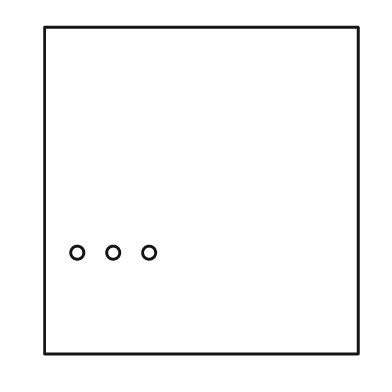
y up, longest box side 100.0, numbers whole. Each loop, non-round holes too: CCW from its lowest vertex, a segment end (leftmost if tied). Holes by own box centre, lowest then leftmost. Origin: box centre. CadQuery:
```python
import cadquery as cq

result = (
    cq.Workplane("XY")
    .moveTo(-48.0, -50.0)
    .lineTo(48.0, -50.0)
    .lineTo(48.0, 50.0)
    .lineTo(-48.0, 50.0)
    .close()
    .moveTo(-38.0, -19.0)
    .circle(2.0)
    .moveTo(-27.0, -19.0)
    .circle(2.0)
    .moveTo(-16.0, -19.0)
    .circle(2.0)
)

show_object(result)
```